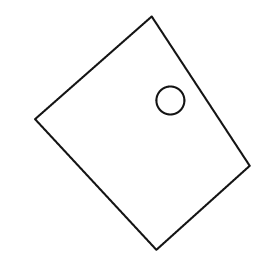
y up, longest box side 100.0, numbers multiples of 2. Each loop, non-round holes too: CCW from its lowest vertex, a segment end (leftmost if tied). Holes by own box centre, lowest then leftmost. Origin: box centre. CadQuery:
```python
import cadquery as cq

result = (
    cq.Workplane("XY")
    .moveTo(6.0, -50.0)
    .lineTo(46.0, -14.0)
    .lineTo(4.0, 50.0)
    .lineTo(-46.0, 6.0)
    .close()
    .moveTo(12.0, 14.0)
    .circle(6.0)
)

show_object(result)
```